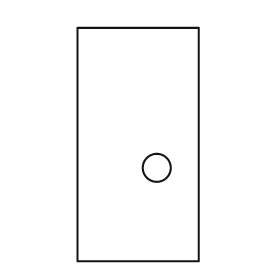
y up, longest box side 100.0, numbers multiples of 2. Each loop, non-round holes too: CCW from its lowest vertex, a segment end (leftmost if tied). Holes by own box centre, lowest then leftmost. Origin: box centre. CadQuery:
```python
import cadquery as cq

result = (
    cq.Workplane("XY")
    .moveTo(-26.0, -50.0)
    .lineTo(26.0, -50.0)
    .lineTo(26.0, 50.0)
    .lineTo(-26.0, 50.0)
    .close()
    .moveTo(8.0, -10.0)
    .circle(6.0)
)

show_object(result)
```